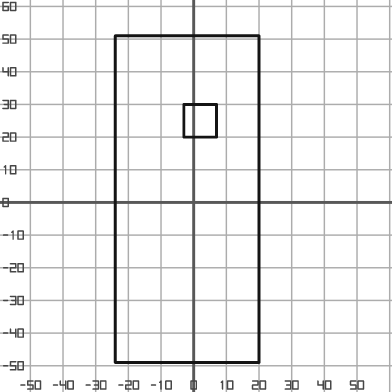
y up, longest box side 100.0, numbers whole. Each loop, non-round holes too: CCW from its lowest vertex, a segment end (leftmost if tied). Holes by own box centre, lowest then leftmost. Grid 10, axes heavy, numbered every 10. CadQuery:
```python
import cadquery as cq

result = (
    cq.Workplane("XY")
    .moveTo(-24.0, -49.0)
    .lineTo(20.0, -49.0)
    .lineTo(20.0, 51.0)
    .lineTo(-24.0, 51.0)
    .close()
    .moveTo(-3.0, 20.0)
    .lineTo(7.0, 20.0)
    .lineTo(7.0, 30.0)
    .lineTo(-3.0, 30.0)
    .close()
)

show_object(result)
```